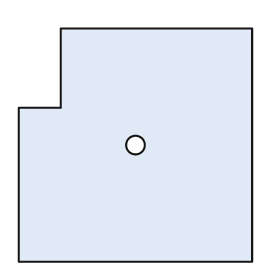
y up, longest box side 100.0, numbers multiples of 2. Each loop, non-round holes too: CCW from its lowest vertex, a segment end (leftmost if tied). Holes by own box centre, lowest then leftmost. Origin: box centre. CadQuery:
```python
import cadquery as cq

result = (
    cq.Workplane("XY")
    .moveTo(-50.0, -50.0)
    .lineTo(50.0, -50.0)
    .lineTo(50.0, 50.0)
    .lineTo(-32.0, 50.0)
    .lineTo(-32.0, 16.0)
    .lineTo(-50.0, 16.0)
    .close()
    .moveTo(0.0, 0.0)
    .circle(4.0)
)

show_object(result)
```